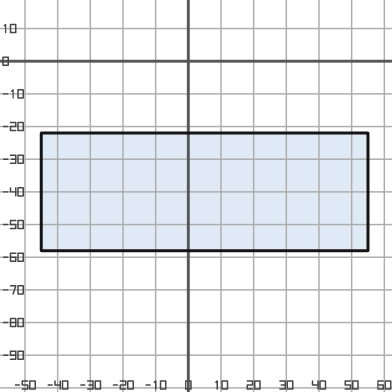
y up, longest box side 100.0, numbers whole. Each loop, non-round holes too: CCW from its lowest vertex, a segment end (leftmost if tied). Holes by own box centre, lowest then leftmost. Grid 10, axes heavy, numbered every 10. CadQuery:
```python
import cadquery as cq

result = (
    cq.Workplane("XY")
    .moveTo(-45.0, -58.0)
    .lineTo(55.0, -58.0)
    .lineTo(55.0, -22.0)
    .lineTo(-45.0, -22.0)
    .close()
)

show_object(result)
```